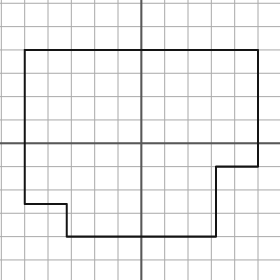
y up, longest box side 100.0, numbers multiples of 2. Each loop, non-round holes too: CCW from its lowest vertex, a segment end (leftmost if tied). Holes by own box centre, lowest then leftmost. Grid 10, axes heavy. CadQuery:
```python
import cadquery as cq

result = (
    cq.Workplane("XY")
    .moveTo(-32.0, -40.0)
    .lineTo(32.0, -40.0)
    .lineTo(32.0, -10.0)
    .lineTo(50.0, -10.0)
    .lineTo(50.0, 40.0)
    .lineTo(-50.0, 40.0)
    .lineTo(-50.0, -26.0)
    .lineTo(-32.0, -26.0)
    .close()
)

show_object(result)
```